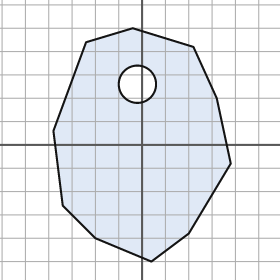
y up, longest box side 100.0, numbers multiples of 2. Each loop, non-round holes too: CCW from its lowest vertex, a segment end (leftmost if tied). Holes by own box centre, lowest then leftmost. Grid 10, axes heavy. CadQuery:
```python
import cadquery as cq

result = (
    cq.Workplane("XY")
    .moveTo(4.0, -50.0)
    .lineTo(20.0, -38.0)
    .lineTo(38.0, -8.0)
    .lineTo(32.0, 20.0)
    .lineTo(22.0, 42.0)
    .lineTo(-4.0, 50.0)
    .lineTo(-24.0, 44.0)
    .lineTo(-38.0, 6.0)
    .lineTo(-34.0, -26.0)
    .lineTo(-20.0, -40.0)
    .close()
    .moveTo(-2.0, 26.0)
    .circle(8.0)
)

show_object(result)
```